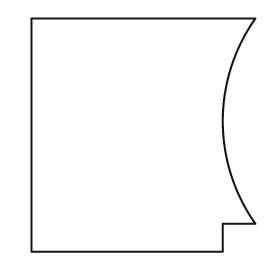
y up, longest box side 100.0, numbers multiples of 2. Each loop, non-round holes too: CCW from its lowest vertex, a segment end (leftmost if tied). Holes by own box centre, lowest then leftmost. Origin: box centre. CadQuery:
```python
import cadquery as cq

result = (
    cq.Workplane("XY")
    .moveTo(-48.0, -50.0)
    .lineTo(34.0, -50.0)
    .lineTo(34.0, -38.0)
    .lineTo(48.0, -38.0)
    .threePointArc((34.0, 6.0), (48.0, 50.0))
    .lineTo(-48.0, 50.0)
    .close()
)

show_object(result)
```